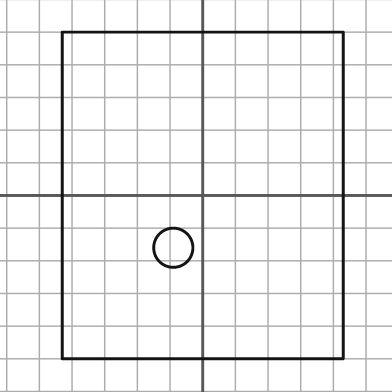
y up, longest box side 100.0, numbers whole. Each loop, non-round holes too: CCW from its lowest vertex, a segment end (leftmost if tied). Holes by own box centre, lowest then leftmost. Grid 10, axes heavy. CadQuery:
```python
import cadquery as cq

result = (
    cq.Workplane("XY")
    .moveTo(-43.0, -50.0)
    .lineTo(43.0, -50.0)
    .lineTo(43.0, 50.0)
    .lineTo(-43.0, 50.0)
    .close()
    .moveTo(-9.0, -16.0)
    .circle(6.0)
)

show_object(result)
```